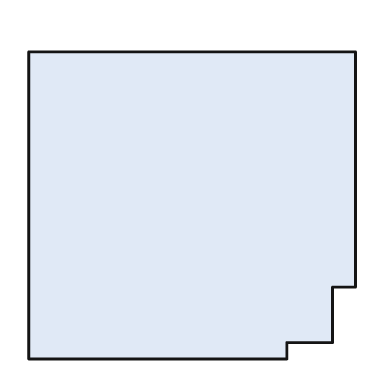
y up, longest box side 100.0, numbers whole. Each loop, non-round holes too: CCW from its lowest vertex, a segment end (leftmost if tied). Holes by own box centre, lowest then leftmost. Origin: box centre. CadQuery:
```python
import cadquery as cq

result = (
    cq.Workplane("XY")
    .moveTo(-50.0, -47.0)
    .lineTo(29.0, -47.0)
    .lineTo(29.0, -42.0)
    .lineTo(43.0, -42.0)
    .lineTo(43.0, -25.0)
    .lineTo(50.0, -25.0)
    .lineTo(50.0, 47.0)
    .lineTo(-50.0, 47.0)
    .close()
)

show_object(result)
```